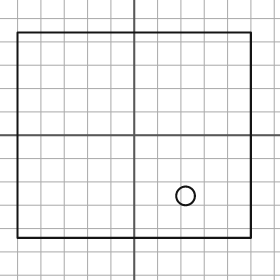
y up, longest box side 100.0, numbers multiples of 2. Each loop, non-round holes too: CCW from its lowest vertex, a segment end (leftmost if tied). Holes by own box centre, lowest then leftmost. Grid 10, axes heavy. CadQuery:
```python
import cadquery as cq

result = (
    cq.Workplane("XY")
    .moveTo(-50.0, -44.0)
    .lineTo(50.0, -44.0)
    .lineTo(50.0, 44.0)
    .lineTo(-50.0, 44.0)
    .close()
    .moveTo(22.0, -26.0)
    .circle(4.0)
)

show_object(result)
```